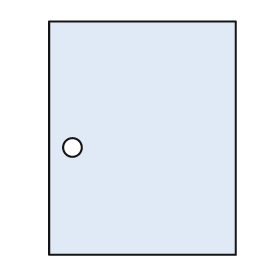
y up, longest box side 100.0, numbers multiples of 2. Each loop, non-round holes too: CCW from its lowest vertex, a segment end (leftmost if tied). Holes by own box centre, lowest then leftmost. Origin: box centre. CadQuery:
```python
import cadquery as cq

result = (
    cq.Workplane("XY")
    .moveTo(-40.0, -50.0)
    .lineTo(40.0, -50.0)
    .lineTo(40.0, 50.0)
    .lineTo(-40.0, 50.0)
    .close()
    .moveTo(-30.0, -4.0)
    .circle(4.0)
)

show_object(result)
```